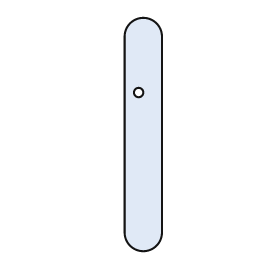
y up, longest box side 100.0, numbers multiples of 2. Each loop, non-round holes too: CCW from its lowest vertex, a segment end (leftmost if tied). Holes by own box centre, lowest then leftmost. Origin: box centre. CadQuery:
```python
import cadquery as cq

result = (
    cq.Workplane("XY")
    .moveTo(-8.0, -42.0)
    .threePointArc((0.0, -50.0), (8.0, -42.0))
    .lineTo(8.0, 42.0)
    .threePointArc((0.0, 50.0), (-8.0, 42.0))
    .close()
    .moveTo(-2.0, 18.0)
    .circle(2.0)
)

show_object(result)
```